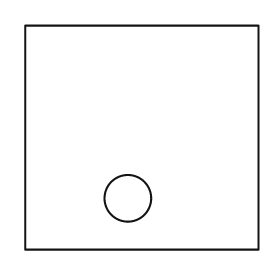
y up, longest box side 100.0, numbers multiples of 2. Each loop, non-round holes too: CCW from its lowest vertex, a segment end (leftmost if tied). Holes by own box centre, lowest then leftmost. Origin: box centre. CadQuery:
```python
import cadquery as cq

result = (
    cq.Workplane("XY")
    .moveTo(-50.0, -48.0)
    .lineTo(50.0, -48.0)
    .lineTo(50.0, 48.0)
    .lineTo(-50.0, 48.0)
    .close()
    .moveTo(-6.0, -26.0)
    .circle(10.0)
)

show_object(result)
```